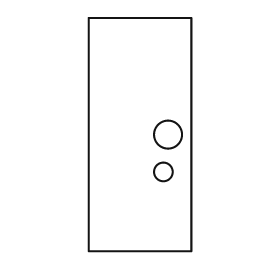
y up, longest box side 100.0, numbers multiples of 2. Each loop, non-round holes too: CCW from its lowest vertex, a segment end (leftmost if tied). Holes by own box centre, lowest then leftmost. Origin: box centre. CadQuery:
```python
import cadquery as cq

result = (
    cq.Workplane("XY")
    .moveTo(-22.0, -50.0)
    .lineTo(22.0, -50.0)
    .lineTo(22.0, 50.0)
    .lineTo(-22.0, 50.0)
    .close()
    .moveTo(10.0, -16.0)
    .circle(4.0)
    .moveTo(12.0, 0.0)
    .circle(6.0)
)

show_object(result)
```